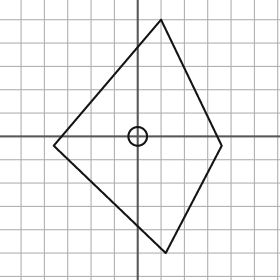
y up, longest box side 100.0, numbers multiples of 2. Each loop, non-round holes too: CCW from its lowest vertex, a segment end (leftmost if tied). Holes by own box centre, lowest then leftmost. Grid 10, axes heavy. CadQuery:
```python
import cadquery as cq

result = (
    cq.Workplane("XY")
    .moveTo(12.0, -50.0)
    .lineTo(36.0, -4.0)
    .lineTo(10.0, 50.0)
    .lineTo(-36.0, -4.0)
    .close()
    .moveTo(0.0, 0.0)
    .circle(4.0)
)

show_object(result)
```